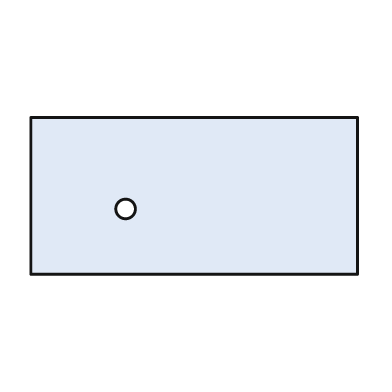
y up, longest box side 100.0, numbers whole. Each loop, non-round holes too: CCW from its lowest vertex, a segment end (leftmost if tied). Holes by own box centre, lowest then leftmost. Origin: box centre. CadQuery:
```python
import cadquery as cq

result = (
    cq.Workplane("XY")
    .moveTo(-50.0, -24.0)
    .lineTo(50.0, -24.0)
    .lineTo(50.0, 24.0)
    .lineTo(-50.0, 24.0)
    .close()
    .moveTo(-21.0, -4.0)
    .circle(3.0)
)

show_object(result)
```